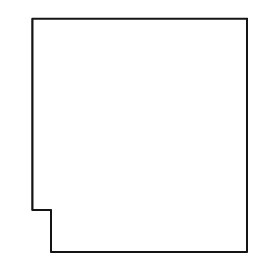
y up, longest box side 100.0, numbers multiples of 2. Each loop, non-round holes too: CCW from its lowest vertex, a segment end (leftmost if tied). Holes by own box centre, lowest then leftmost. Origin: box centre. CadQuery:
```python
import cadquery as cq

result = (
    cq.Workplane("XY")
    .moveTo(-38.0, -50.0)
    .lineTo(46.0, -50.0)
    .lineTo(46.0, 50.0)
    .lineTo(-46.0, 50.0)
    .lineTo(-46.0, -32.0)
    .lineTo(-38.0, -32.0)
    .close()
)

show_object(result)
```